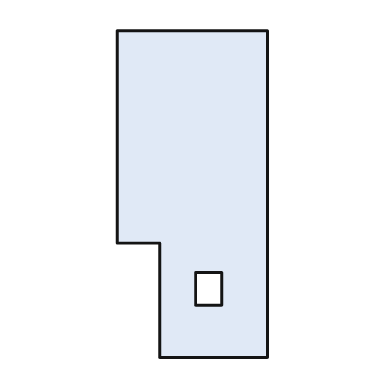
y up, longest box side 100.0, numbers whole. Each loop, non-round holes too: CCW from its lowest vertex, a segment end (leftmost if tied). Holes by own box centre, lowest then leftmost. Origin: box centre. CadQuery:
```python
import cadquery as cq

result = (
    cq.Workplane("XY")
    .moveTo(-10.0, -50.0)
    .lineTo(23.0, -50.0)
    .lineTo(23.0, 50.0)
    .lineTo(-23.0, 50.0)
    .lineTo(-23.0, -15.0)
    .lineTo(-10.0, -15.0)
    .close()
    .moveTo(1.0, -34.0)
    .lineTo(9.0, -34.0)
    .lineTo(9.0, -24.0)
    .lineTo(1.0, -24.0)
    .close()
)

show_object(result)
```